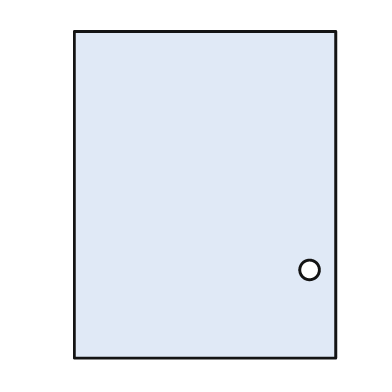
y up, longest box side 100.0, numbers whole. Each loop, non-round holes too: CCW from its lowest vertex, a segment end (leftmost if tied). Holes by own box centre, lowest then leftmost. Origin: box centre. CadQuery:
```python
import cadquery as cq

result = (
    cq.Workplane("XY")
    .moveTo(-40.0, -50.0)
    .lineTo(40.0, -50.0)
    .lineTo(40.0, 50.0)
    .lineTo(-40.0, 50.0)
    .close()
    .moveTo(32.0, -23.0)
    .circle(3.0)
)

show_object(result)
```